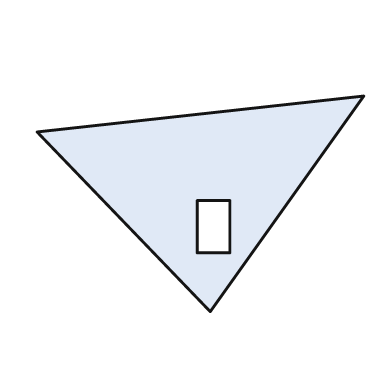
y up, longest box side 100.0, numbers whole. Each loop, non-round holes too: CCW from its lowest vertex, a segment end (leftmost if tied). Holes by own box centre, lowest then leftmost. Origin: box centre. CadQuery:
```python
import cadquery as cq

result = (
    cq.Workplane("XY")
    .moveTo(3.0, -33.0)
    .lineTo(50.0, 33.0)
    .lineTo(-50.0, 22.0)
    .close()
    .moveTo(-1.0, -15.0)
    .lineTo(9.0, -15.0)
    .lineTo(9.0, 1.0)
    .lineTo(-1.0, 1.0)
    .close()
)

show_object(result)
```